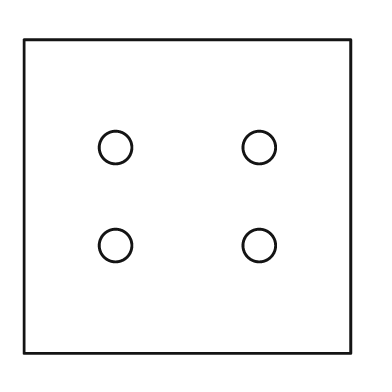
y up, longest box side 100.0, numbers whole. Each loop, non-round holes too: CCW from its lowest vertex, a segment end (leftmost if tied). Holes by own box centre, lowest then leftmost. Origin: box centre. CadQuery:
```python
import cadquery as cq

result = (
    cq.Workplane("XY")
    .moveTo(-50.0, -48.0)
    .lineTo(50.0, -48.0)
    .lineTo(50.0, 48.0)
    .lineTo(-50.0, 48.0)
    .close()
    .moveTo(-22.0, -15.0)
    .circle(5.0)
    .moveTo(22.0, -15.0)
    .circle(5.0)
    .moveTo(-22.0, 15.0)
    .circle(5.0)
    .moveTo(22.0, 15.0)
    .circle(5.0)
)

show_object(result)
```